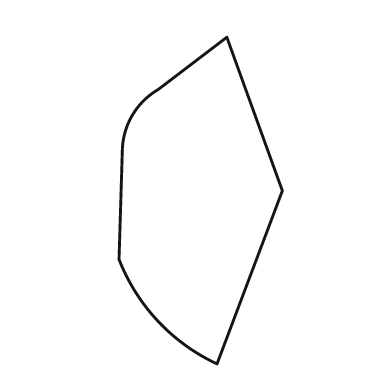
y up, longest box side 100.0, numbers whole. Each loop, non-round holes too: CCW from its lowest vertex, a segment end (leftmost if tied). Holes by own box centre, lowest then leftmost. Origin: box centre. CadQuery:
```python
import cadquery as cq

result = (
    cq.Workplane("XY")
    .moveTo(5.0, -50.0)
    .lineTo(25.0, 3.0)
    .lineTo(8.0, 50.0)
    .lineTo(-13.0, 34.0)
    .threePointArc((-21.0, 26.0), (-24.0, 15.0))
    .lineTo(-25.0, -18.0)
    .threePointArc((-13.0, -37.0), (5.0, -50.0))
    .close()
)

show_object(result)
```